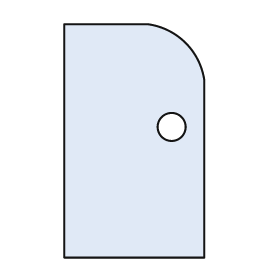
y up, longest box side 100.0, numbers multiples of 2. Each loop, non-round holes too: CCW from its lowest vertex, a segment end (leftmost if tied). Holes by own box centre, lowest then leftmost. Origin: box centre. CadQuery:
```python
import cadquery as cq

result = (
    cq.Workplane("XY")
    .moveTo(-30.0, -50.0)
    .lineTo(30.0, -50.0)
    .lineTo(30.0, 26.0)
    .threePointArc((22.0, 42.0), (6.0, 50.0))
    .lineTo(-30.0, 50.0)
    .close()
    .moveTo(16.0, 6.0)
    .circle(6.0)
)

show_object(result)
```